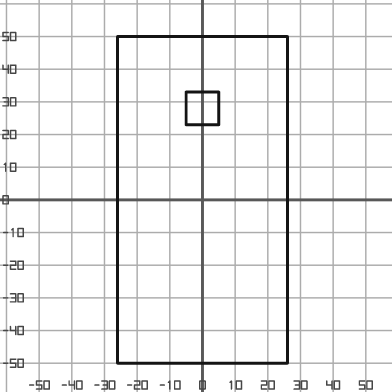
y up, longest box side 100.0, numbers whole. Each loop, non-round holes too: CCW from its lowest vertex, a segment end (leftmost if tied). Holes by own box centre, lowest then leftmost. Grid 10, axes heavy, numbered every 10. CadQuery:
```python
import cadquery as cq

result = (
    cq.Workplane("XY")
    .moveTo(-26.0, -50.0)
    .lineTo(26.0, -50.0)
    .lineTo(26.0, 50.0)
    .lineTo(-26.0, 50.0)
    .close()
    .moveTo(-5.0, 23.0)
    .lineTo(5.0, 23.0)
    .lineTo(5.0, 33.0)
    .lineTo(-5.0, 33.0)
    .close()
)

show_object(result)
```